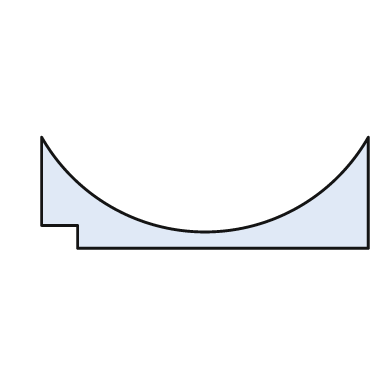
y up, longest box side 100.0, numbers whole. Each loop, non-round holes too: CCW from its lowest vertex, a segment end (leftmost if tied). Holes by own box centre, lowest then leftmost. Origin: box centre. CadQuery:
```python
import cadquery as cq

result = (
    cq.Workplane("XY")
    .moveTo(-39.0, -17.0)
    .lineTo(50.0, -17.0)
    .lineTo(50.0, 17.0)
    .threePointArc((0.0, -12.0), (-50.0, 17.0))
    .lineTo(-50.0, -10.0)
    .lineTo(-39.0, -10.0)
    .close()
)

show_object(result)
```